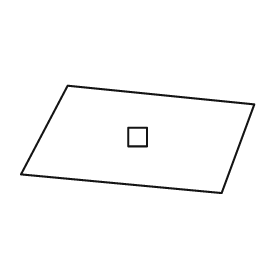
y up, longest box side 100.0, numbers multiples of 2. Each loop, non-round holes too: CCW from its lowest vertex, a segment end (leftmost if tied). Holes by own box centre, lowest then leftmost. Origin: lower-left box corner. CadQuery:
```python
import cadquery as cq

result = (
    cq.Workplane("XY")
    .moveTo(86.0, 0.0)
    .lineTo(100.0, 38.0)
    .lineTo(20.0, 46.0)
    .lineTo(0.0, 8.0)
    .close()
    .moveTo(46.0, 20.0)
    .lineTo(54.0, 20.0)
    .lineTo(54.0, 28.0)
    .lineTo(46.0, 28.0)
    .close()
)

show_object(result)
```